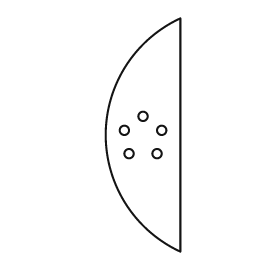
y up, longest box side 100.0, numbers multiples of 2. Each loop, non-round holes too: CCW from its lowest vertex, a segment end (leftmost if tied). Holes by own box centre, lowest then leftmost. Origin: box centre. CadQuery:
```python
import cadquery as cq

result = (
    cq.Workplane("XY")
    .moveTo(16.0, -50.0)
    .lineTo(16.0, 50.0)
    .threePointArc((-16.0, 0.0), (16.0, -50.0))
    .close()
    .moveTo(-6.0, -8.0)
    .circle(2.0)
    .moveTo(6.0, -8.0)
    .circle(2.0)
    .moveTo(-8.0, 2.0)
    .circle(2.0)
    .moveTo(8.0, 2.0)
    .circle(2.0)
    .moveTo(0.0, 8.0)
    .circle(2.0)
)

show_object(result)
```